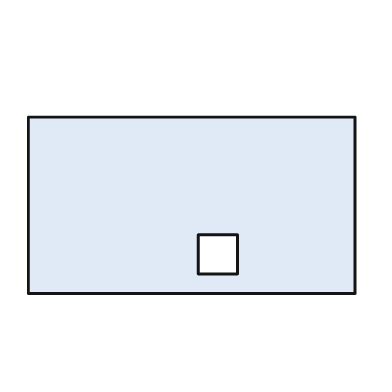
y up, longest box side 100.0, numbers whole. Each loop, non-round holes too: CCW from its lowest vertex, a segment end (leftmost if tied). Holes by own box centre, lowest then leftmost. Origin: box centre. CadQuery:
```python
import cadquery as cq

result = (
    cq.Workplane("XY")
    .moveTo(-50.0, -27.0)
    .lineTo(50.0, -27.0)
    .lineTo(50.0, 27.0)
    .lineTo(-50.0, 27.0)
    .close()
    .moveTo(2.0, -21.0)
    .lineTo(14.0, -21.0)
    .lineTo(14.0, -9.0)
    .lineTo(2.0, -9.0)
    .close()
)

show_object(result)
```